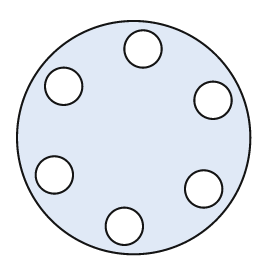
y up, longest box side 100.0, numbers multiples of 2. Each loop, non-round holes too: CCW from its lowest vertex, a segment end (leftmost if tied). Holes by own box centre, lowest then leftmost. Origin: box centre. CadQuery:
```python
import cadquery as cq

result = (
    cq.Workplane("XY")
    .moveTo(0.0, 0.0)
    .circle(50.0)
    .moveTo(-4.0, -38.0)
    .circle(8.0)
    .moveTo(30.0, -22.0)
    .circle(8.0)
    .moveTo(-34.0, -16.0)
    .circle(8.0)
    .moveTo(34.0, 16.0)
    .circle(8.0)
    .moveTo(-30.0, 22.0)
    .circle(8.0)
    .moveTo(4.0, 38.0)
    .circle(8.0)
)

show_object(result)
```